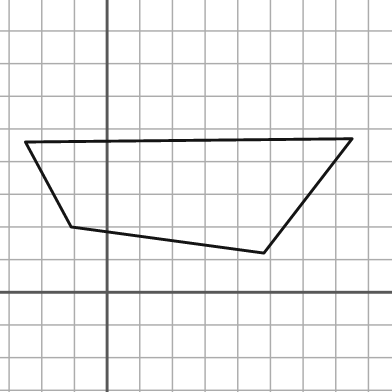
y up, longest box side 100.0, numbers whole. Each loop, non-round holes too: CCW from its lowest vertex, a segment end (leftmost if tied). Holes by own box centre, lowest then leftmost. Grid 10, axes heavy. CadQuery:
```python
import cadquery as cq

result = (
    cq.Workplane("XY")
    .moveTo(48.0, 12.0)
    .lineTo(75.0, 47.0)
    .lineTo(-25.0, 46.0)
    .lineTo(-11.0, 20.0)
    .close()
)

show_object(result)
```